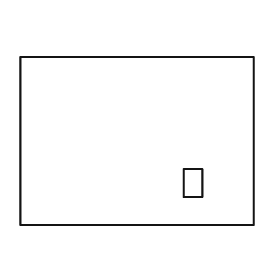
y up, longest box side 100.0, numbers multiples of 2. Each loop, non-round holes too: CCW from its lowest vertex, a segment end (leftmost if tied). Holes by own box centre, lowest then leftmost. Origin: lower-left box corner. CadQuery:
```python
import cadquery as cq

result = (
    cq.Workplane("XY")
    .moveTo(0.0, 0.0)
    .lineTo(100.0, 0.0)
    .lineTo(100.0, 72.0)
    .lineTo(0.0, 72.0)
    .close()
    .moveTo(70.0, 12.0)
    .lineTo(78.0, 12.0)
    .lineTo(78.0, 24.0)
    .lineTo(70.0, 24.0)
    .close()
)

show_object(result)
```